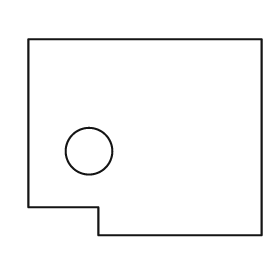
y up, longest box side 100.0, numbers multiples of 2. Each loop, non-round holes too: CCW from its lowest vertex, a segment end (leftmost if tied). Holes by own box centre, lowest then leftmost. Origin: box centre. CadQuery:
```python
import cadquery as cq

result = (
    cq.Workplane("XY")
    .moveTo(-20.0, -42.0)
    .lineTo(50.0, -42.0)
    .lineTo(50.0, 42.0)
    .lineTo(-50.0, 42.0)
    .lineTo(-50.0, -30.0)
    .lineTo(-20.0, -30.0)
    .close()
    .moveTo(-24.0, -6.0)
    .circle(10.0)
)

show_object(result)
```